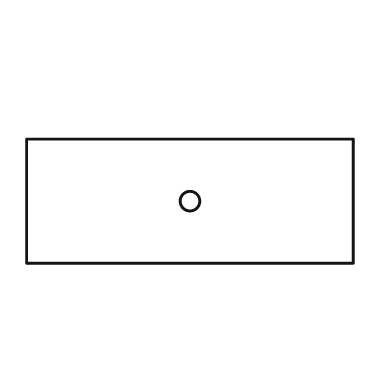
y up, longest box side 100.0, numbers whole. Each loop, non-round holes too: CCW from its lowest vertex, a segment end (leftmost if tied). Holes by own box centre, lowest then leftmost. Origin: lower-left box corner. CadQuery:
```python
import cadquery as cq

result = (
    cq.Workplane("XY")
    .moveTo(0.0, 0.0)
    .lineTo(100.0, 0.0)
    .lineTo(100.0, 38.0)
    .lineTo(0.0, 38.0)
    .close()
    .moveTo(50.0, 19.0)
    .circle(3.0)
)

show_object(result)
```